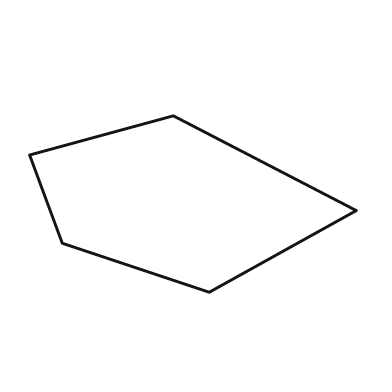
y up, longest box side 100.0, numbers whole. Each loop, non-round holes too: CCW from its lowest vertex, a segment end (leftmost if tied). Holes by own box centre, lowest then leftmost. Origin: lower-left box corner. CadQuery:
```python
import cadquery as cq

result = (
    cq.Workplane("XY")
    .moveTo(55.0, 0.0)
    .lineTo(100.0, 25.0)
    .lineTo(44.0, 54.0)
    .lineTo(0.0, 42.0)
    .lineTo(10.0, 15.0)
    .close()
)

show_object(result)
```